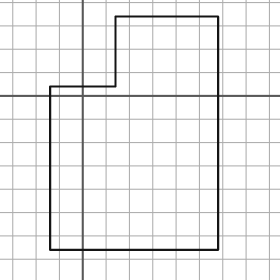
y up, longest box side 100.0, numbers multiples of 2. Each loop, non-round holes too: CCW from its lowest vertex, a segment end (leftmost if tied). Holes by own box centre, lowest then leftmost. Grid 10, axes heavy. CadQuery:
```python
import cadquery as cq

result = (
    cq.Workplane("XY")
    .moveTo(-14.0, -66.0)
    .lineTo(58.0, -66.0)
    .lineTo(58.0, 34.0)
    .lineTo(14.0, 34.0)
    .lineTo(14.0, 4.0)
    .lineTo(-14.0, 4.0)
    .close()
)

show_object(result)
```